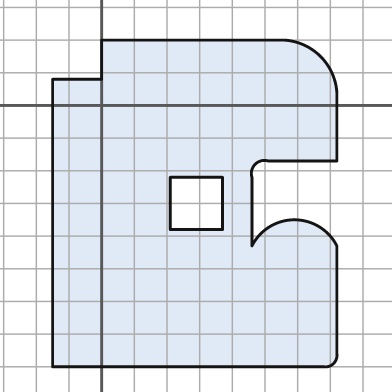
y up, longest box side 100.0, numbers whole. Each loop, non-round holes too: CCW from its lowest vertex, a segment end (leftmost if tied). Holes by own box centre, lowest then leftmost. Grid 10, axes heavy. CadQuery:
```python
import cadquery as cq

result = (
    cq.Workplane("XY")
    .moveTo(-15.0, -80.0)
    .lineTo(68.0, -80.0)
    .threePointArc((71.0, -79.0), (72.0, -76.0))
    .lineTo(72.0, -43.0)
    .threePointArc((59.0, -35.0), (46.0, -43.0))
    .lineTo(46.0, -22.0)
    .threePointArc((47.0, -18.0), (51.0, -17.0))
    .lineTo(72.0, -17.0)
    .lineTo(72.0, 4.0)
    .threePointArc((67.0, 15.0), (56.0, 20.0))
    .lineTo(0.0, 20.0)
    .lineTo(0.0, 8.0)
    .lineTo(-15.0, 8.0)
    .close()
    .moveTo(21.0, -38.0)
    .lineTo(37.0, -38.0)
    .lineTo(37.0, -22.0)
    .lineTo(21.0, -22.0)
    .close()
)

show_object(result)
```